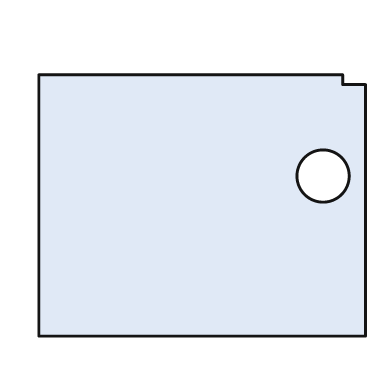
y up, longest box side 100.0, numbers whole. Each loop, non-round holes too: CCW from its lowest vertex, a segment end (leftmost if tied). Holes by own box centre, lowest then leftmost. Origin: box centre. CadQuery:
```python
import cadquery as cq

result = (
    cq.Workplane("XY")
    .moveTo(-50.0, -40.0)
    .lineTo(50.0, -40.0)
    .lineTo(50.0, 37.0)
    .lineTo(43.0, 37.0)
    .lineTo(43.0, 40.0)
    .lineTo(-50.0, 40.0)
    .close()
    .moveTo(37.0, 9.0)
    .circle(8.0)
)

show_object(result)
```